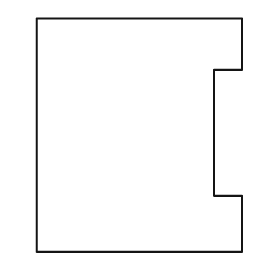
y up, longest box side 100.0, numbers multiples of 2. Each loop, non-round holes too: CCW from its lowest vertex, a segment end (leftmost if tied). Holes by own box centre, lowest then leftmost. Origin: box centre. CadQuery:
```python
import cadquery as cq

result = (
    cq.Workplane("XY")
    .moveTo(-44.0, -50.0)
    .lineTo(44.0, -50.0)
    .lineTo(44.0, -26.0)
    .lineTo(32.0, -26.0)
    .lineTo(32.0, 28.0)
    .lineTo(44.0, 28.0)
    .lineTo(44.0, 50.0)
    .lineTo(-44.0, 50.0)
    .close()
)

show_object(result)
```